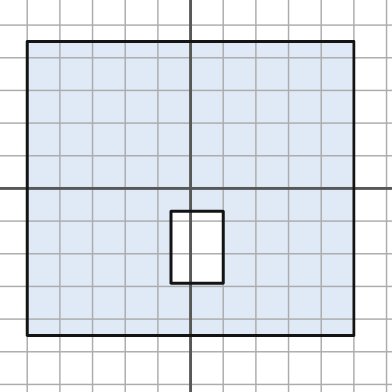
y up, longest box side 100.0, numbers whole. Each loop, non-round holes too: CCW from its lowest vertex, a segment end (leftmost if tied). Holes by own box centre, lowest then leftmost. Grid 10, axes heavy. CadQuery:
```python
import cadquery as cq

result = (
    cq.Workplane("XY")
    .moveTo(-50.0, -45.0)
    .lineTo(50.0, -45.0)
    .lineTo(50.0, 45.0)
    .lineTo(-50.0, 45.0)
    .close()
    .moveTo(-6.0, -29.0)
    .lineTo(10.0, -29.0)
    .lineTo(10.0, -7.0)
    .lineTo(-6.0, -7.0)
    .close()
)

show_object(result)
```